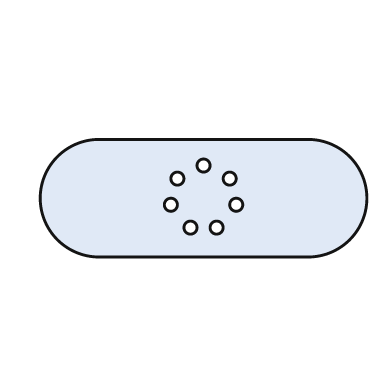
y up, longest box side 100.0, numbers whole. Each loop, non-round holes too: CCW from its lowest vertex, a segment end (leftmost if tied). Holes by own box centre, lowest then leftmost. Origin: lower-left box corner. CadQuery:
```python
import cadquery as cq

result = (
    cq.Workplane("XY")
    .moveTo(18.0, 0.0)
    .lineTo(82.0, 0.0)
    .threePointArc((100.0, 18.0), (82.0, 36.0))
    .lineTo(18.0, 36.0)
    .threePointArc((0.0, 18.0), (18.0, 0.0))
    .close()
    .moveTo(46.0, 9.0)
    .circle(2.0)
    .moveTo(54.0, 9.0)
    .circle(2.0)
    .moveTo(40.0, 16.0)
    .circle(2.0)
    .moveTo(60.0, 16.0)
    .circle(2.0)
    .moveTo(42.0, 24.0)
    .circle(2.0)
    .moveTo(58.0, 24.0)
    .circle(2.0)
    .moveTo(50.0, 28.0)
    .circle(2.0)
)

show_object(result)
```